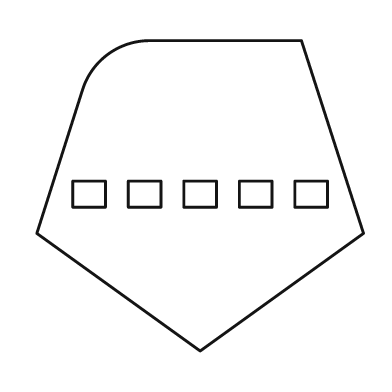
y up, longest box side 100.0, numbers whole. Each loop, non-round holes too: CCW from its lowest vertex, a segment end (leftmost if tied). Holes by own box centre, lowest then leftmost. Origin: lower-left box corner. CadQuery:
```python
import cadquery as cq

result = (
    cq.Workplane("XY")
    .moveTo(50.0, 0.0)
    .lineTo(100.0, 36.0)
    .lineTo(81.0, 95.0)
    .lineTo(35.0, 95.0)
    .threePointArc((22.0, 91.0), (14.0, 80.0))
    .lineTo(0.0, 36.0)
    .close()
    .moveTo(11.0, 44.0)
    .lineTo(21.0, 44.0)
    .lineTo(21.0, 52.0)
    .lineTo(11.0, 52.0)
    .close()
    .moveTo(28.0, 44.0)
    .lineTo(38.0, 44.0)
    .lineTo(38.0, 52.0)
    .lineTo(28.0, 52.0)
    .close()
    .moveTo(45.0, 44.0)
    .lineTo(55.0, 44.0)
    .lineTo(55.0, 52.0)
    .lineTo(45.0, 52.0)
    .close()
    .moveTo(62.0, 44.0)
    .lineTo(72.0, 44.0)
    .lineTo(72.0, 52.0)
    .lineTo(62.0, 52.0)
    .close()
    .moveTo(79.0, 44.0)
    .lineTo(89.0, 44.0)
    .lineTo(89.0, 52.0)
    .lineTo(79.0, 52.0)
    .close()
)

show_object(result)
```